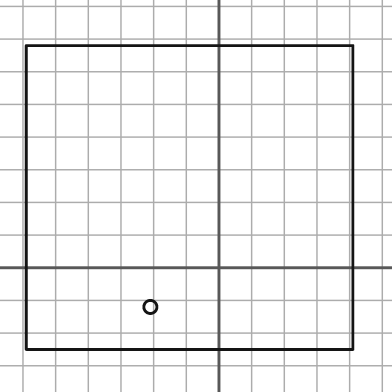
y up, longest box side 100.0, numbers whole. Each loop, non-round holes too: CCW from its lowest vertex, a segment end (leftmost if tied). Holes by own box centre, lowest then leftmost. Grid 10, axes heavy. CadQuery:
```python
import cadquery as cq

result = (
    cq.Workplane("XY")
    .moveTo(-59.0, -25.0)
    .lineTo(41.0, -25.0)
    .lineTo(41.0, 68.0)
    .lineTo(-59.0, 68.0)
    .close()
    .moveTo(-21.0, -12.0)
    .circle(2.0)
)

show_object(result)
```